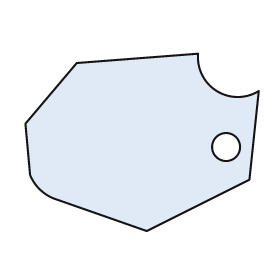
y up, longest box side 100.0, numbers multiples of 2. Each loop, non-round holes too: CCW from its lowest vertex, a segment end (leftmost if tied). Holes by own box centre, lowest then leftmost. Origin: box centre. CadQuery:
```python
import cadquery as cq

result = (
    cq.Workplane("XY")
    .moveTo(2.0, -38.0)
    .lineTo(46.0, -16.0)
    .lineTo(50.0, 22.0)
    .threePointArc((32.0, 22.0), (24.0, 38.0))
    .lineTo(-28.0, 34.0)
    .lineTo(-50.0, 8.0)
    .lineTo(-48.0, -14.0)
    .threePointArc((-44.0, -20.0), (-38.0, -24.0))
    .close()
    .moveTo(36.0, -2.0)
    .circle(6.0)
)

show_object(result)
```